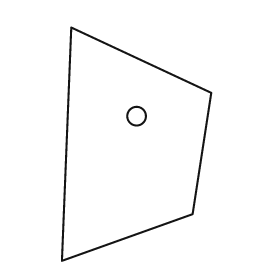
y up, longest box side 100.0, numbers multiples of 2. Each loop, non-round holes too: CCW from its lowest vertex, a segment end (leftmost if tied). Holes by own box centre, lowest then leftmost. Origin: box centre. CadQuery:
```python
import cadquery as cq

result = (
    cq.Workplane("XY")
    .moveTo(-32.0, -50.0)
    .lineTo(24.0, -30.0)
    .lineTo(32.0, 22.0)
    .lineTo(-28.0, 50.0)
    .close()
    .moveTo(0.0, 12.0)
    .circle(4.0)
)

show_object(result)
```